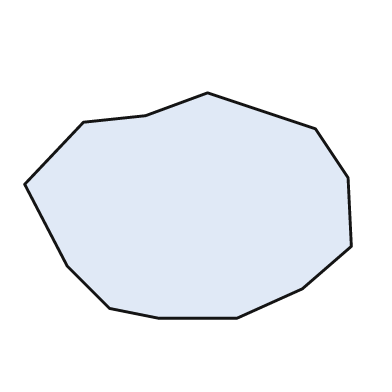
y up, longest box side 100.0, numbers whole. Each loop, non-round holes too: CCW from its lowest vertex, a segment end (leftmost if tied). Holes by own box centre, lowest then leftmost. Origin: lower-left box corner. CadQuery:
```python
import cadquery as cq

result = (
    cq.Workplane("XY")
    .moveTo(41.0, 0.0)
    .lineTo(65.0, 0.0)
    .lineTo(85.0, 9.0)
    .lineTo(100.0, 22.0)
    .lineTo(99.0, 43.0)
    .lineTo(89.0, 58.0)
    .lineTo(56.0, 69.0)
    .lineTo(37.0, 62.0)
    .lineTo(18.0, 60.0)
    .lineTo(0.0, 41.0)
    .lineTo(13.0, 16.0)
    .lineTo(26.0, 3.0)
    .close()
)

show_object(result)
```